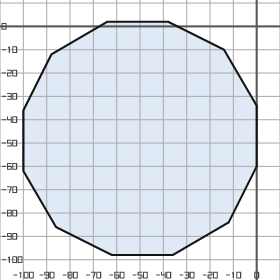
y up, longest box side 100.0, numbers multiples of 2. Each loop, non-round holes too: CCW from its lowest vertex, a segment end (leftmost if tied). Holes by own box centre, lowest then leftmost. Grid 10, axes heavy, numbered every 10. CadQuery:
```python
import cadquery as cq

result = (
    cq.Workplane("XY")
    .moveTo(-62.0, -98.0)
    .lineTo(-36.0, -98.0)
    .lineTo(-12.0, -84.0)
    .lineTo(0.0, -60.0)
    .lineTo(0.0, -34.0)
    .lineTo(-14.0, -10.0)
    .lineTo(-38.0, 2.0)
    .lineTo(-64.0, 2.0)
    .lineTo(-88.0, -12.0)
    .lineTo(-100.0, -36.0)
    .lineTo(-100.0, -62.0)
    .lineTo(-86.0, -86.0)
    .close()
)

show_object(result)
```